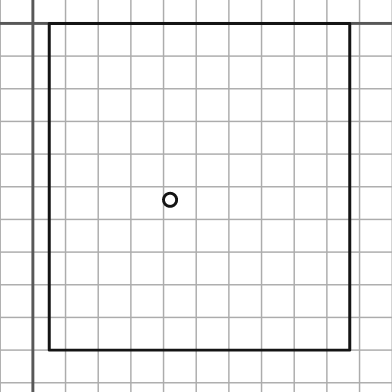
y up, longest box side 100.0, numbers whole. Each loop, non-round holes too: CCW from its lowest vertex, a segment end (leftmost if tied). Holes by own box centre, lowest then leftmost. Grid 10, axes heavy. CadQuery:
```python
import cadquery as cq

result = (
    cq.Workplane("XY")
    .moveTo(5.0, -100.0)
    .lineTo(97.0, -100.0)
    .lineTo(97.0, 0.0)
    .lineTo(5.0, 0.0)
    .close()
    .moveTo(42.0, -54.0)
    .circle(2.0)
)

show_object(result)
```